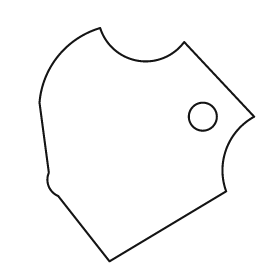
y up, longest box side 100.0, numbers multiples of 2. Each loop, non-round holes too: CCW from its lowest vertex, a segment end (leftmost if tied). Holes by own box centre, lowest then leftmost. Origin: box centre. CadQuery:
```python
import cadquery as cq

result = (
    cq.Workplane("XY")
    .moveTo(-16.0, -50.0)
    .lineTo(34.0, -20.0)
    .threePointArc((34.0, -2.0), (46.0, 12.0))
    .lineTo(16.0, 44.0)
    .threePointArc((-4.0, 36.0), (-20.0, 50.0))
    .threePointArc((-38.0, 38.0), (-46.0, 18.0))
    .lineTo(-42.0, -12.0)
    .threePointArc((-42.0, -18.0), (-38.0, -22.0))
    .close()
    .moveTo(24.0, 12.0)
    .circle(6.0)
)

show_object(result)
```